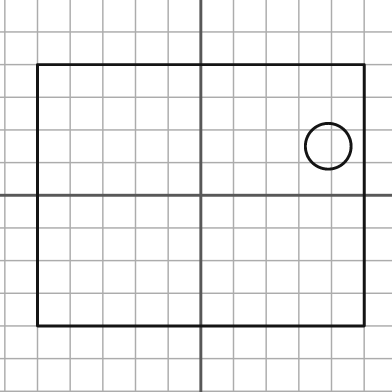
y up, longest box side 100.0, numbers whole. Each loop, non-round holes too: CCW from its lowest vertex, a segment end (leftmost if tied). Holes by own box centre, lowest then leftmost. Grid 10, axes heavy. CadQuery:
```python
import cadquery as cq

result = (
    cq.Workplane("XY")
    .moveTo(-50.0, -40.0)
    .lineTo(50.0, -40.0)
    .lineTo(50.0, 40.0)
    .lineTo(-50.0, 40.0)
    .close()
    .moveTo(39.0, 15.0)
    .circle(7.0)
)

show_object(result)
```